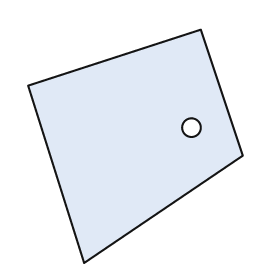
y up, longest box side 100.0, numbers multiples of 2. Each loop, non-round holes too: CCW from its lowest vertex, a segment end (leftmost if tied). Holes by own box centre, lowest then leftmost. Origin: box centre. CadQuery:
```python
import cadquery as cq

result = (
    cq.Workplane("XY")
    .moveTo(-22.0, -50.0)
    .lineTo(46.0, -4.0)
    .lineTo(28.0, 50.0)
    .lineTo(-46.0, 26.0)
    .close()
    .moveTo(24.0, 8.0)
    .circle(4.0)
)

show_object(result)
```